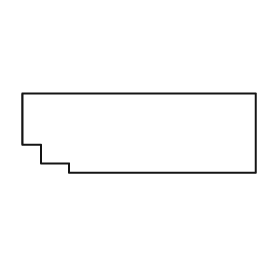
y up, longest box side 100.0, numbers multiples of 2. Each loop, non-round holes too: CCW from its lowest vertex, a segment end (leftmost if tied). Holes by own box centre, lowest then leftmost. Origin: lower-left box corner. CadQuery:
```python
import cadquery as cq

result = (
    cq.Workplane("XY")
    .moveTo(20.0, 0.0)
    .lineTo(100.0, 0.0)
    .lineTo(100.0, 34.0)
    .lineTo(0.0, 34.0)
    .lineTo(0.0, 12.0)
    .lineTo(8.0, 12.0)
    .lineTo(8.0, 4.0)
    .lineTo(20.0, 4.0)
    .close()
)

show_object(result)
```